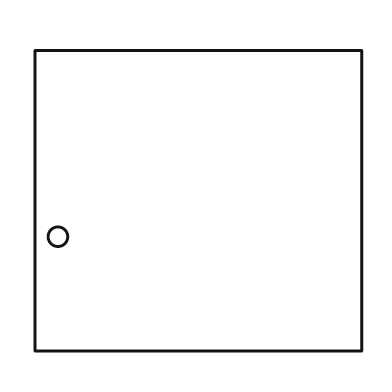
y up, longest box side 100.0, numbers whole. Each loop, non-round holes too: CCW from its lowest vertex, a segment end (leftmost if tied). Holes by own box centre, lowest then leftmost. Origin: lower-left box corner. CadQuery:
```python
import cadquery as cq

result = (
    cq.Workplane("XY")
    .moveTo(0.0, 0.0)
    .lineTo(100.0, 0.0)
    .lineTo(100.0, 92.0)
    .lineTo(0.0, 92.0)
    .close()
    .moveTo(7.0, 35.0)
    .circle(3.0)
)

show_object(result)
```